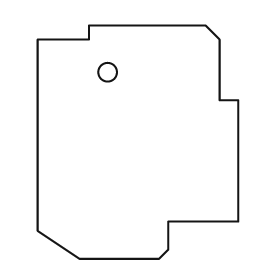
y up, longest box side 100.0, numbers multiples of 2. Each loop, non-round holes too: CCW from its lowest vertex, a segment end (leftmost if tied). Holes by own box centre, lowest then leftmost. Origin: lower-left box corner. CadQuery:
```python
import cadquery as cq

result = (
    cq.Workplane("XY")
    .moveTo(18.0, 0.0)
    .lineTo(52.0, 0.0)
    .lineTo(56.0, 4.0)
    .lineTo(56.0, 16.0)
    .lineTo(86.0, 16.0)
    .lineTo(86.0, 68.0)
    .lineTo(78.0, 68.0)
    .lineTo(78.0, 94.0)
    .lineTo(72.0, 100.0)
    .lineTo(22.0, 100.0)
    .lineTo(22.0, 94.0)
    .lineTo(0.0, 94.0)
    .lineTo(0.0, 12.0)
    .close()
    .moveTo(30.0, 80.0)
    .circle(4.0)
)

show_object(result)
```